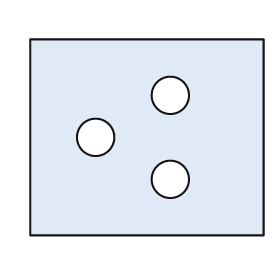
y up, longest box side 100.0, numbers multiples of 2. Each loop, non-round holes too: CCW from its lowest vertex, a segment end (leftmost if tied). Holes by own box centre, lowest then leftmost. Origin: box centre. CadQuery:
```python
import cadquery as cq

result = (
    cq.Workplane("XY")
    .moveTo(-50.0, -42.0)
    .lineTo(50.0, -42.0)
    .lineTo(50.0, 42.0)
    .lineTo(-50.0, 42.0)
    .close()
    .moveTo(10.0, -18.0)
    .circle(8.0)
    .moveTo(-22.0, 0.0)
    .circle(8.0)
    .moveTo(10.0, 18.0)
    .circle(8.0)
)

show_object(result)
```